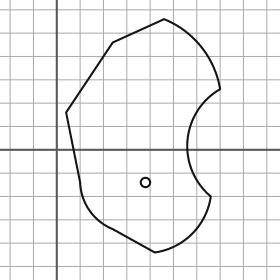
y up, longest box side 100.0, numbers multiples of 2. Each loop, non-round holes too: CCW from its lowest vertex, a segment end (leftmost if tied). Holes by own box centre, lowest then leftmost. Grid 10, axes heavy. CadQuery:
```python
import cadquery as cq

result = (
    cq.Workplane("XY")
    .moveTo(42.0, -44.0)
    .threePointArc((58.0, -36.0), (66.0, -20.0))
    .threePointArc((56.0, 4.0), (70.0, 26.0))
    .threePointArc((62.0, 44.0), (46.0, 56.0))
    .lineTo(24.0, 46.0)
    .lineTo(4.0, 16.0)
    .lineTo(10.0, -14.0)
    .threePointArc((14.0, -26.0), (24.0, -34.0))
    .close()
    .moveTo(38.0, -14.0)
    .circle(2.0)
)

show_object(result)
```